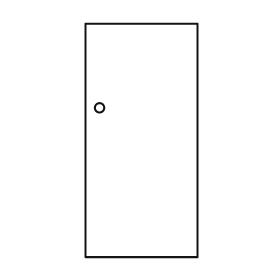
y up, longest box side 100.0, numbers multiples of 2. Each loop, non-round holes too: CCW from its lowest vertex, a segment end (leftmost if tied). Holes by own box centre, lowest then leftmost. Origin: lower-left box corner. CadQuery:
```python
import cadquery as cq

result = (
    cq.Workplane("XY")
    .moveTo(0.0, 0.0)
    .lineTo(48.0, 0.0)
    .lineTo(48.0, 100.0)
    .lineTo(0.0, 100.0)
    .close()
    .moveTo(6.0, 64.0)
    .circle(2.0)
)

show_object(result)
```